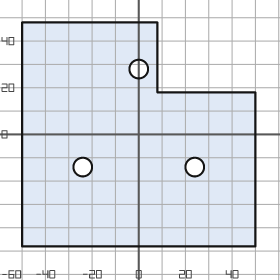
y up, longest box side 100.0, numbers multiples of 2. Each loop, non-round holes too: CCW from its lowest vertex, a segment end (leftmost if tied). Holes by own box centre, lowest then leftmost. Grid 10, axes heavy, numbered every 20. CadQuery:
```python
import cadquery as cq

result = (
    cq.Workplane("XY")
    .moveTo(-50.0, -48.0)
    .lineTo(50.0, -48.0)
    .lineTo(50.0, 18.0)
    .lineTo(8.0, 18.0)
    .lineTo(8.0, 48.0)
    .lineTo(-50.0, 48.0)
    .close()
    .moveTo(-24.0, -14.0)
    .circle(4.0)
    .moveTo(24.0, -14.0)
    .circle(4.0)
    .moveTo(0.0, 28.0)
    .circle(4.0)
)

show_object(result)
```